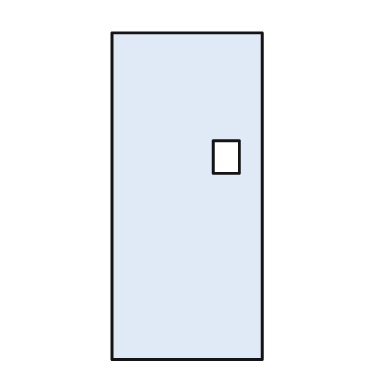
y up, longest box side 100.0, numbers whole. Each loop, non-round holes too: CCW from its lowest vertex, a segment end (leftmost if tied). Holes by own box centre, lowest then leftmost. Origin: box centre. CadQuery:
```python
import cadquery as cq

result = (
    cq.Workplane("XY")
    .moveTo(-23.0, -50.0)
    .lineTo(23.0, -50.0)
    .lineTo(23.0, 50.0)
    .lineTo(-23.0, 50.0)
    .close()
    .moveTo(8.0, 7.0)
    .lineTo(16.0, 7.0)
    .lineTo(16.0, 17.0)
    .lineTo(8.0, 17.0)
    .close()
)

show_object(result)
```